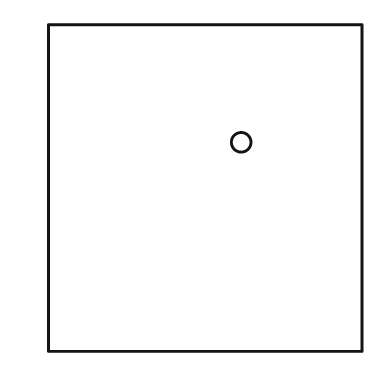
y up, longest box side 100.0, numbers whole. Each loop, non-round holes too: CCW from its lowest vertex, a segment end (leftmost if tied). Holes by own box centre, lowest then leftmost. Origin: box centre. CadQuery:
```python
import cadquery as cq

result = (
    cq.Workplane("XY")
    .moveTo(-48.0, -50.0)
    .lineTo(48.0, -50.0)
    .lineTo(48.0, 50.0)
    .lineTo(-48.0, 50.0)
    .close()
    .moveTo(11.0, 14.0)
    .circle(3.0)
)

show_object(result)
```